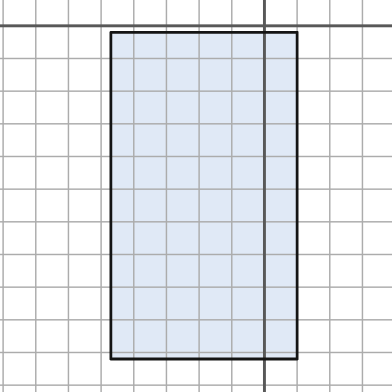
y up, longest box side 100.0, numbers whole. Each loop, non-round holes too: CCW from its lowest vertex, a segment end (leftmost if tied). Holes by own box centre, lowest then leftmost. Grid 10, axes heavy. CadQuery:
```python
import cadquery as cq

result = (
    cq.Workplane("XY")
    .moveTo(-47.0, -102.0)
    .lineTo(10.0, -102.0)
    .lineTo(10.0, -2.0)
    .lineTo(-47.0, -2.0)
    .close()
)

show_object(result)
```